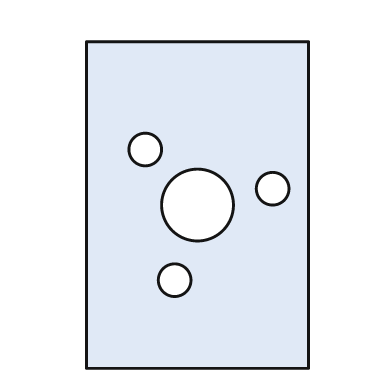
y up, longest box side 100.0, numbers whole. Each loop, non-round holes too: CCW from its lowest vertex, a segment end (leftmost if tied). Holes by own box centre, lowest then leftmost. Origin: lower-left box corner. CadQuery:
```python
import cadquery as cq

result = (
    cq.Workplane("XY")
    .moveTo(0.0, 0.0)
    .lineTo(68.0, 0.0)
    .lineTo(68.0, 100.0)
    .lineTo(0.0, 100.0)
    .close()
    .moveTo(27.0, 27.0)
    .circle(5.0)
    .moveTo(34.0, 50.0)
    .circle(11.0)
    .moveTo(57.0, 55.0)
    .circle(5.0)
    .moveTo(18.0, 67.0)
    .circle(5.0)
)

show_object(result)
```